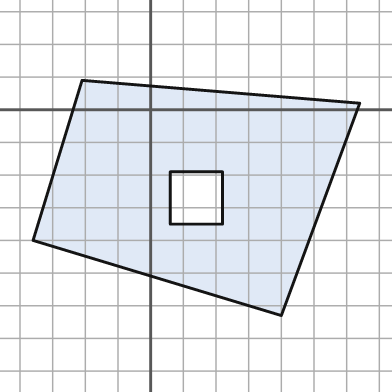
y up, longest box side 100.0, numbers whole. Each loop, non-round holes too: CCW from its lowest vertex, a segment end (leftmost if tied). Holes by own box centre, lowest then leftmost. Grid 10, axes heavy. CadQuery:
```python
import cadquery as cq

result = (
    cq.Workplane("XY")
    .moveTo(40.0, -63.0)
    .lineTo(64.0, 2.0)
    .lineTo(-21.0, 9.0)
    .lineTo(-36.0, -40.0)
    .close()
    .moveTo(6.0, -35.0)
    .lineTo(22.0, -35.0)
    .lineTo(22.0, -19.0)
    .lineTo(6.0, -19.0)
    .close()
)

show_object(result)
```